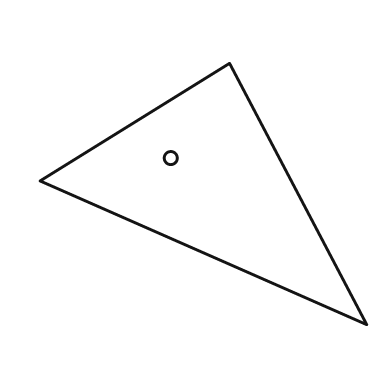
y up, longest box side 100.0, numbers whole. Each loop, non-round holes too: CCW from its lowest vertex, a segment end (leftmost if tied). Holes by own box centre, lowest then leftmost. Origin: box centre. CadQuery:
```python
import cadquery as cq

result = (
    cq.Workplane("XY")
    .moveTo(50.0, -40.0)
    .lineTo(8.0, 40.0)
    .lineTo(-50.0, 4.0)
    .close()
    .moveTo(-10.0, 11.0)
    .circle(2.0)
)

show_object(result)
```